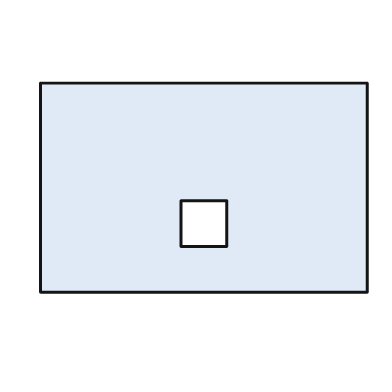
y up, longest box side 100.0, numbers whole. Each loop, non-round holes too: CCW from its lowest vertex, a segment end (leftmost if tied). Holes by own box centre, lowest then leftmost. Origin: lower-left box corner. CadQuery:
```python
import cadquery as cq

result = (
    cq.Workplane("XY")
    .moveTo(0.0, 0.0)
    .lineTo(100.0, 0.0)
    .lineTo(100.0, 64.0)
    .lineTo(0.0, 64.0)
    .close()
    .moveTo(43.0, 14.0)
    .lineTo(57.0, 14.0)
    .lineTo(57.0, 28.0)
    .lineTo(43.0, 28.0)
    .close()
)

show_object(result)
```